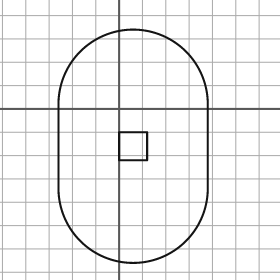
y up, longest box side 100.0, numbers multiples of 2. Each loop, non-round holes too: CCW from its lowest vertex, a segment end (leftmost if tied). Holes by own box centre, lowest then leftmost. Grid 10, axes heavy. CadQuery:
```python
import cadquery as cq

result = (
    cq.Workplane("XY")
    .moveTo(-26.0, -34.0)
    .threePointArc((6.0, -66.0), (38.0, -34.0))
    .lineTo(38.0, 2.0)
    .threePointArc((6.0, 34.0), (-26.0, 2.0))
    .close()
    .moveTo(0.0, -22.0)
    .lineTo(12.0, -22.0)
    .lineTo(12.0, -10.0)
    .lineTo(0.0, -10.0)
    .close()
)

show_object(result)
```